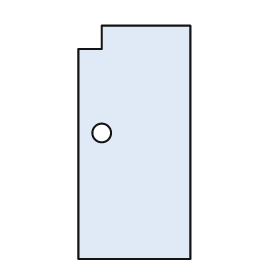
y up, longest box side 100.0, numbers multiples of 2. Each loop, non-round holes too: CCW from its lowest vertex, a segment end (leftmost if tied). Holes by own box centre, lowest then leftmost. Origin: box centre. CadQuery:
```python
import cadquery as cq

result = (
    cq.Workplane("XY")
    .moveTo(-24.0, -50.0)
    .lineTo(24.0, -50.0)
    .lineTo(24.0, 50.0)
    .lineTo(-14.0, 50.0)
    .lineTo(-14.0, 40.0)
    .lineTo(-24.0, 40.0)
    .close()
    .moveTo(-14.0, 4.0)
    .circle(4.0)
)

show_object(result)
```